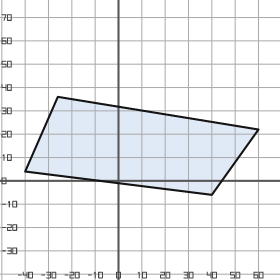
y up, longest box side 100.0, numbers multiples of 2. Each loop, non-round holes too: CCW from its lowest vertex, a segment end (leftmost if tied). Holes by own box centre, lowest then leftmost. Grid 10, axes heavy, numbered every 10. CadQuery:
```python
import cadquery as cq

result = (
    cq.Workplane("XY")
    .moveTo(40.0, -6.0)
    .lineTo(60.0, 22.0)
    .lineTo(-26.0, 36.0)
    .lineTo(-40.0, 4.0)
    .close()
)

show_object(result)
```